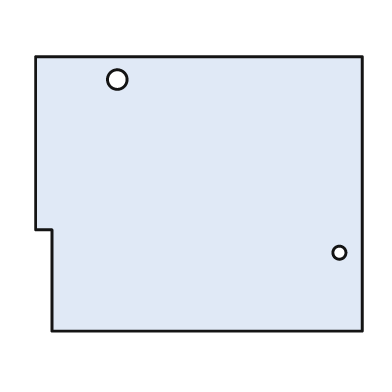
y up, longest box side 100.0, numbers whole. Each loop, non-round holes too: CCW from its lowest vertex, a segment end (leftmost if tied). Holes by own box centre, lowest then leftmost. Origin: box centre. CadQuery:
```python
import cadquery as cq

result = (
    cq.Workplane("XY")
    .moveTo(-45.0, -42.0)
    .lineTo(50.0, -42.0)
    .lineTo(50.0, 42.0)
    .lineTo(-50.0, 42.0)
    .lineTo(-50.0, -11.0)
    .lineTo(-45.0, -11.0)
    .close()
    .moveTo(43.0, -18.0)
    .circle(2.0)
    .moveTo(-25.0, 35.0)
    .circle(3.0)
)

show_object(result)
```